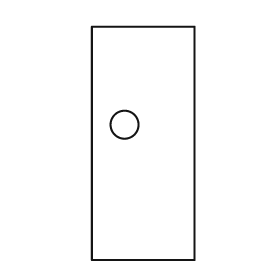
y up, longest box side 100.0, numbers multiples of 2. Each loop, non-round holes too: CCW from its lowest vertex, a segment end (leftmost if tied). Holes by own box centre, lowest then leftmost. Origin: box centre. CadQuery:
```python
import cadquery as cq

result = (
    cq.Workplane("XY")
    .moveTo(-22.0, -50.0)
    .lineTo(22.0, -50.0)
    .lineTo(22.0, 50.0)
    .lineTo(-22.0, 50.0)
    .close()
    .moveTo(-8.0, 8.0)
    .circle(6.0)
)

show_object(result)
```